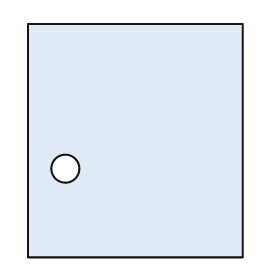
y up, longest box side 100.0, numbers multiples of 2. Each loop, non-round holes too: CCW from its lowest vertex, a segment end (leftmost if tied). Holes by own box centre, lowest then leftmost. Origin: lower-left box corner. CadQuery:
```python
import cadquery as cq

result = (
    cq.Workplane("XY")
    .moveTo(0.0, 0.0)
    .lineTo(92.0, 0.0)
    .lineTo(92.0, 100.0)
    .lineTo(0.0, 100.0)
    .close()
    .moveTo(16.0, 38.0)
    .circle(6.0)
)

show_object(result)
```